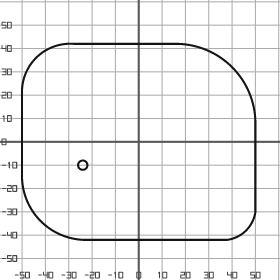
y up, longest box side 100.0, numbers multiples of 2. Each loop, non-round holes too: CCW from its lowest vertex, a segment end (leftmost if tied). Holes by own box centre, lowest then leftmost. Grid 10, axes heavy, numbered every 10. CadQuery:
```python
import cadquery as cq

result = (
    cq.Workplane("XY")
    .moveTo(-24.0, -42.0)
    .lineTo(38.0, -42.0)
    .threePointArc((46.0, -38.0), (50.0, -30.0))
    .lineTo(50.0, 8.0)
    .threePointArc((40.0, 32.0), (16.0, 42.0))
    .lineTo(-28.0, 42.0)
    .threePointArc((-44.0, 36.0), (-50.0, 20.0))
    .lineTo(-50.0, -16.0)
    .threePointArc((-42.0, -34.0), (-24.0, -42.0))
    .close()
    .moveTo(-24.0, -10.0)
    .circle(2.0)
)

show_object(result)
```